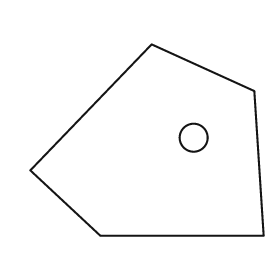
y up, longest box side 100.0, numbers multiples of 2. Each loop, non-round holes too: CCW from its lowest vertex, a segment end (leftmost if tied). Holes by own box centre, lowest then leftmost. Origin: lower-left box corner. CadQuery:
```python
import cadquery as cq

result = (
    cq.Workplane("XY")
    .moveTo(30.0, 0.0)
    .lineTo(100.0, 0.0)
    .lineTo(96.0, 62.0)
    .lineTo(52.0, 82.0)
    .lineTo(0.0, 28.0)
    .close()
    .moveTo(70.0, 42.0)
    .circle(6.0)
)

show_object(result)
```